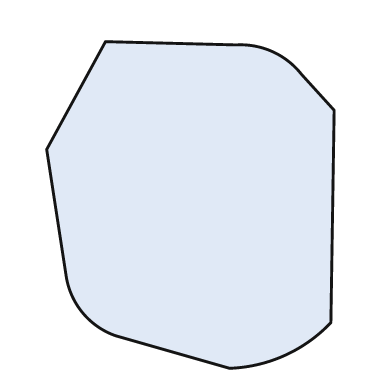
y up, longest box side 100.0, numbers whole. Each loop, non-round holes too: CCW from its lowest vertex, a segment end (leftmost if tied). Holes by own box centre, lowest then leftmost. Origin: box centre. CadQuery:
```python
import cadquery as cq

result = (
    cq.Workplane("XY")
    .moveTo(12.0, -50.0)
    .threePointArc((29.0, -46.0), (43.0, -36.0))
    .lineTo(44.0, 29.0)
    .lineTo(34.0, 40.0)
    .threePointArc((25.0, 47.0), (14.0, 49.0))
    .lineTo(-26.0, 50.0)
    .lineTo(-44.0, 17.0)
    .lineTo(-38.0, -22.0)
    .threePointArc((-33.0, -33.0), (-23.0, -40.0))
    .close()
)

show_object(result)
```